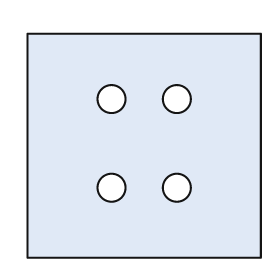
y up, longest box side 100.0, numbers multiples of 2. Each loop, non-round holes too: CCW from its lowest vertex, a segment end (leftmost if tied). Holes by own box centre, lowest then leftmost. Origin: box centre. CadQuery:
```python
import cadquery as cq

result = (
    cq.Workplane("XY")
    .moveTo(-50.0, -48.0)
    .lineTo(50.0, -48.0)
    .lineTo(50.0, 48.0)
    .lineTo(-50.0, 48.0)
    .close()
    .moveTo(-14.0, -18.0)
    .circle(6.0)
    .moveTo(14.0, -18.0)
    .circle(6.0)
    .moveTo(-14.0, 20.0)
    .circle(6.0)
    .moveTo(14.0, 20.0)
    .circle(6.0)
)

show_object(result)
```